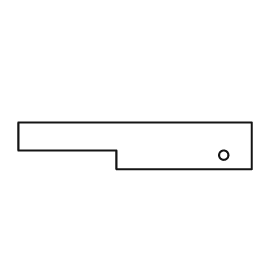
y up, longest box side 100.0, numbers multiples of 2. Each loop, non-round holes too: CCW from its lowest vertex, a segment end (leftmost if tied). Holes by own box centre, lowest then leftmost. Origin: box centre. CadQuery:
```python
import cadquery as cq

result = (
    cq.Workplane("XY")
    .moveTo(-8.0, -10.0)
    .lineTo(50.0, -10.0)
    .lineTo(50.0, 10.0)
    .lineTo(-50.0, 10.0)
    .lineTo(-50.0, -2.0)
    .lineTo(-8.0, -2.0)
    .close()
    .moveTo(38.0, -4.0)
    .circle(2.0)
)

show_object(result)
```